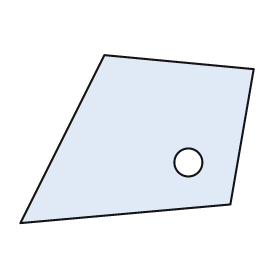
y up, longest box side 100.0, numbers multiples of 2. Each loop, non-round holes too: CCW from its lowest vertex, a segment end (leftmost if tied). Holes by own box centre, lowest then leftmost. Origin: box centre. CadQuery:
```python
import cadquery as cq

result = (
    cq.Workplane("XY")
    .moveTo(-50.0, -36.0)
    .lineTo(40.0, -28.0)
    .lineTo(50.0, 30.0)
    .lineTo(-14.0, 36.0)
    .close()
    .moveTo(22.0, -10.0)
    .circle(6.0)
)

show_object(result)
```